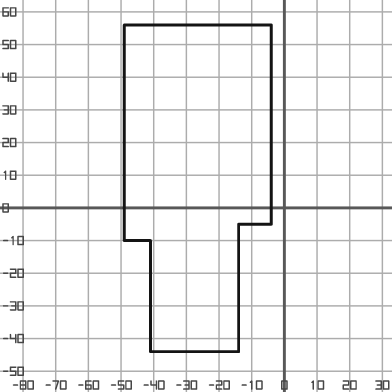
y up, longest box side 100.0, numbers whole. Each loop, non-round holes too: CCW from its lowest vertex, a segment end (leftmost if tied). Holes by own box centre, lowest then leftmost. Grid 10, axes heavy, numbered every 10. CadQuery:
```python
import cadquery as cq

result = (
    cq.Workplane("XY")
    .moveTo(-41.0, -44.0)
    .lineTo(-14.0, -44.0)
    .lineTo(-14.0, -5.0)
    .lineTo(-4.0, -5.0)
    .lineTo(-4.0, 56.0)
    .lineTo(-49.0, 56.0)
    .lineTo(-49.0, -10.0)
    .lineTo(-41.0, -10.0)
    .close()
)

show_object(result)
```